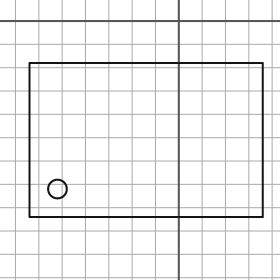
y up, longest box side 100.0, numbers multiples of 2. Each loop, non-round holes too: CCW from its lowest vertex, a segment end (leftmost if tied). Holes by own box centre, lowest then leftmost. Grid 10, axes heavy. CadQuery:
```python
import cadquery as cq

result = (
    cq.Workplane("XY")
    .moveTo(-64.0, -84.0)
    .lineTo(36.0, -84.0)
    .lineTo(36.0, -18.0)
    .lineTo(-64.0, -18.0)
    .close()
    .moveTo(-52.0, -72.0)
    .circle(4.0)
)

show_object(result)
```